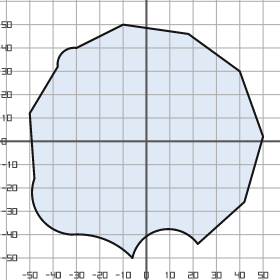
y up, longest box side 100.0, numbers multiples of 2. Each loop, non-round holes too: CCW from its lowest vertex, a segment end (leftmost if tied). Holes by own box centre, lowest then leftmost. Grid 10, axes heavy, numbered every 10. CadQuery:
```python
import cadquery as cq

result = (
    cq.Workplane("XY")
    .moveTo(-6.0, -50.0)
    .threePointArc((6.0, -38.0), (22.0, -44.0))
    .lineTo(42.0, -26.0)
    .lineTo(50.0, 2.0)
    .lineTo(40.0, 30.0)
    .lineTo(18.0, 46.0)
    .lineTo(-10.0, 50.0)
    .lineTo(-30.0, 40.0)
    .threePointArc((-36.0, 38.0), (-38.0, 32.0))
    .lineTo(-50.0, 12.0)
    .lineTo(-48.0, -16.0)
    .threePointArc((-46.0, -32.0), (-32.0, -40.0))
    .threePointArc((-18.0, -42.0), (-6.0, -50.0))
    .close()
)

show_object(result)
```